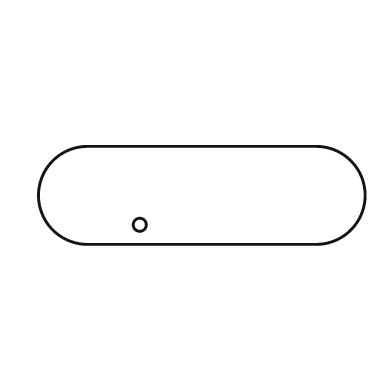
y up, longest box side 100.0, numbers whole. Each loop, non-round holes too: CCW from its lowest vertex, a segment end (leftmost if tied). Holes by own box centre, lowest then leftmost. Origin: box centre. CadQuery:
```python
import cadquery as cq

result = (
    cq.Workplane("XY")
    .moveTo(-35.0, -15.0)
    .lineTo(35.0, -15.0)
    .threePointArc((50.0, 0.0), (35.0, 15.0))
    .lineTo(-35.0, 15.0)
    .threePointArc((-50.0, 0.0), (-35.0, -15.0))
    .close()
    .moveTo(-19.0, -9.0)
    .circle(2.0)
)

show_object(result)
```